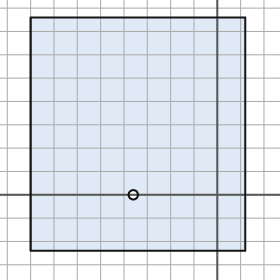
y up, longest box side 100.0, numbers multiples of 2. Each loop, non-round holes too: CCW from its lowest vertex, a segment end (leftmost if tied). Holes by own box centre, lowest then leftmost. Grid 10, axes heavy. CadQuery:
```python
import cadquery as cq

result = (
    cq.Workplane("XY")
    .moveTo(-80.0, -24.0)
    .lineTo(12.0, -24.0)
    .lineTo(12.0, 76.0)
    .lineTo(-80.0, 76.0)
    .close()
    .moveTo(-36.0, 0.0)
    .circle(2.0)
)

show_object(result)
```